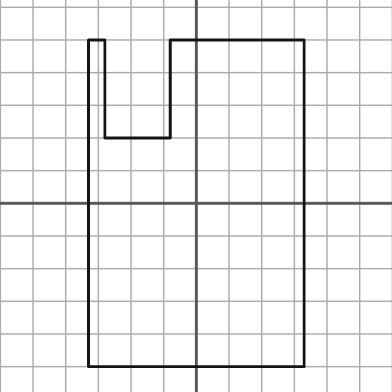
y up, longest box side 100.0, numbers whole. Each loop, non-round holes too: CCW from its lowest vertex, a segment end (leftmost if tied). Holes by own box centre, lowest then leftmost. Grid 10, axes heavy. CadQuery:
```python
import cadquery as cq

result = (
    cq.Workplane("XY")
    .moveTo(-33.0, -50.0)
    .lineTo(33.0, -50.0)
    .lineTo(33.0, 50.0)
    .lineTo(-8.0, 50.0)
    .lineTo(-8.0, 20.0)
    .lineTo(-28.0, 20.0)
    .lineTo(-28.0, 50.0)
    .lineTo(-33.0, 50.0)
    .close()
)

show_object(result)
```